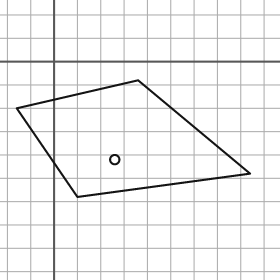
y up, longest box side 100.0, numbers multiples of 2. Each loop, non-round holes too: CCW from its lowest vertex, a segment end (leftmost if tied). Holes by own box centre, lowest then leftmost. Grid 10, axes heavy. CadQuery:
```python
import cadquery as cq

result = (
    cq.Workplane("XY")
    .moveTo(10.0, -58.0)
    .lineTo(84.0, -48.0)
    .lineTo(36.0, -8.0)
    .lineTo(-16.0, -20.0)
    .close()
    .moveTo(26.0, -42.0)
    .circle(2.0)
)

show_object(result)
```